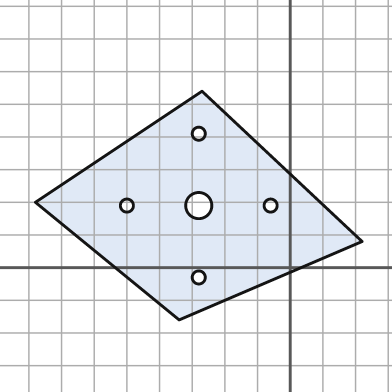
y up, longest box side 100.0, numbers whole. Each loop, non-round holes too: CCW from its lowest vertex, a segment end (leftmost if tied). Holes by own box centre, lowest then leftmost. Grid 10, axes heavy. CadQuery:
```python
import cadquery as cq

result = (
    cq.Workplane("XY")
    .moveTo(-34.0, -16.0)
    .lineTo(22.0, 8.0)
    .lineTo(-27.0, 54.0)
    .lineTo(-78.0, 20.0)
    .close()
    .moveTo(-28.0, -3.0)
    .circle(2.0)
    .moveTo(-50.0, 19.0)
    .circle(2.0)
    .moveTo(-28.0, 19.0)
    .circle(4.0)
    .moveTo(-6.0, 19.0)
    .circle(2.0)
    .moveTo(-28.0, 41.0)
    .circle(2.0)
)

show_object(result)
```